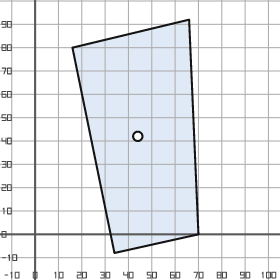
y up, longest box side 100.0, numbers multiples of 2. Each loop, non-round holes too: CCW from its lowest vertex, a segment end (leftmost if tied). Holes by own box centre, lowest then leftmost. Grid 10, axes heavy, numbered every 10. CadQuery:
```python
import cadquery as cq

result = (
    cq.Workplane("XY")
    .moveTo(34.0, -8.0)
    .lineTo(70.0, 0.0)
    .lineTo(66.0, 92.0)
    .lineTo(16.0, 80.0)
    .close()
    .moveTo(44.0, 42.0)
    .circle(2.0)
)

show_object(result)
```